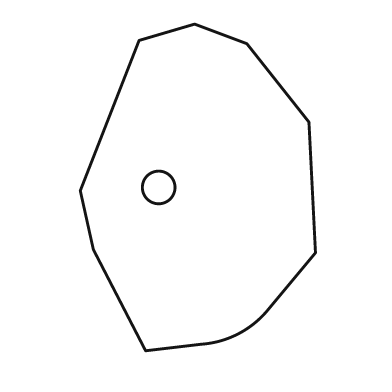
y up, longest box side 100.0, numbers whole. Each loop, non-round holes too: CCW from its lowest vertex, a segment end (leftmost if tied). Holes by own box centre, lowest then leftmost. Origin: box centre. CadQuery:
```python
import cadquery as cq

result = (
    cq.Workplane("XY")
    .moveTo(-16.0, -50.0)
    .lineTo(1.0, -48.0)
    .threePointArc((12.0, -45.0), (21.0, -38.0))
    .lineTo(36.0, -20.0)
    .lineTo(34.0, 20.0)
    .lineTo(15.0, 44.0)
    .lineTo(-1.0, 50.0)
    .lineTo(-18.0, 45.0)
    .lineTo(-36.0, -1.0)
    .lineTo(-32.0, -19.0)
    .close()
    .moveTo(-12.0, 0.0)
    .circle(5.0)
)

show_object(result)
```